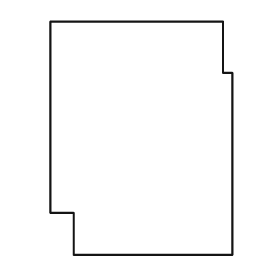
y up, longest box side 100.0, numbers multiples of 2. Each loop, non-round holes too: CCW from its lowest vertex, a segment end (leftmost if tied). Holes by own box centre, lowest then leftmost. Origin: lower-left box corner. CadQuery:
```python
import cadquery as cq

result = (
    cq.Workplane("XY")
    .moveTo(10.0, 0.0)
    .lineTo(78.0, 0.0)
    .lineTo(78.0, 78.0)
    .lineTo(74.0, 78.0)
    .lineTo(74.0, 100.0)
    .lineTo(0.0, 100.0)
    .lineTo(0.0, 18.0)
    .lineTo(10.0, 18.0)
    .close()
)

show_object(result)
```